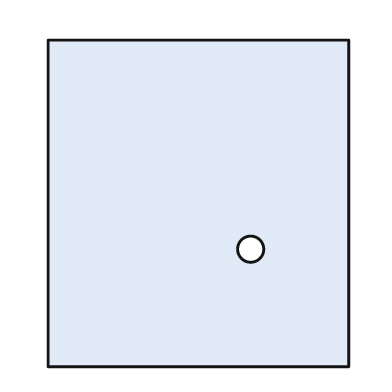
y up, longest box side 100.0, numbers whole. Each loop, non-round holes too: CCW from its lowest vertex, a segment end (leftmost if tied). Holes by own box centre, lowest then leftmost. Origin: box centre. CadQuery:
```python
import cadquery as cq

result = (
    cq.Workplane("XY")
    .moveTo(-46.0, -50.0)
    .lineTo(46.0, -50.0)
    .lineTo(46.0, 50.0)
    .lineTo(-46.0, 50.0)
    .close()
    .moveTo(16.0, -14.0)
    .circle(4.0)
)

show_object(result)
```